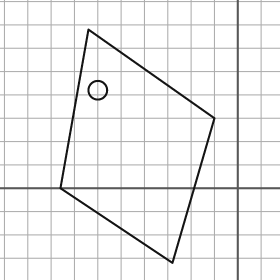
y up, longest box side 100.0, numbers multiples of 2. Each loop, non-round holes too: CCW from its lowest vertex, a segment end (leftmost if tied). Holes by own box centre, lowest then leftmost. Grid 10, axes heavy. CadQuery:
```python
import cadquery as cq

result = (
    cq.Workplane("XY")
    .moveTo(-28.0, -32.0)
    .lineTo(-10.0, 30.0)
    .lineTo(-64.0, 68.0)
    .lineTo(-76.0, 0.0)
    .close()
    .moveTo(-60.0, 42.0)
    .circle(4.0)
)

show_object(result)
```